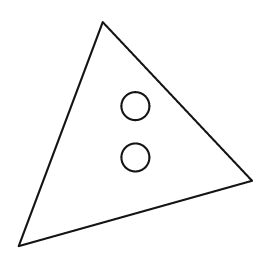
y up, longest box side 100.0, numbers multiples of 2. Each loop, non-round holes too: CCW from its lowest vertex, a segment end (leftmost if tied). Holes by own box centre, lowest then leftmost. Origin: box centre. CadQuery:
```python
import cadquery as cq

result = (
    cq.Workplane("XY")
    .moveTo(-50.0, -48.0)
    .lineTo(50.0, -20.0)
    .lineTo(-14.0, 48.0)
    .close()
    .moveTo(0.0, -10.0)
    .circle(6.0)
    .moveTo(0.0, 12.0)
    .circle(6.0)
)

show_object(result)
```